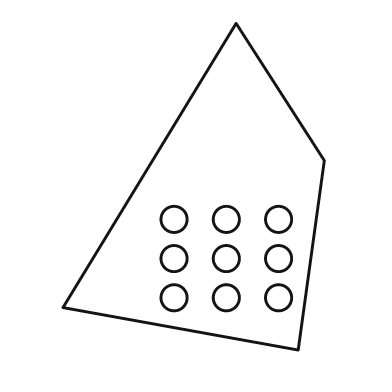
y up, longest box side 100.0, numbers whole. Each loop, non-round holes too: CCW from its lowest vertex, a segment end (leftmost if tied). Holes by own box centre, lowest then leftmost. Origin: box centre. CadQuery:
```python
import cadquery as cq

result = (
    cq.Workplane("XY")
    .moveTo(32.0, -50.0)
    .lineTo(40.0, 8.0)
    .lineTo(13.0, 50.0)
    .lineTo(-40.0, -37.0)
    .close()
    .moveTo(-6.0, -34.0)
    .circle(4.0)
    .moveTo(10.0, -34.0)
    .circle(4.0)
    .moveTo(26.0, -34.0)
    .circle(4.0)
    .moveTo(-6.0, -22.0)
    .circle(4.0)
    .moveTo(10.0, -22.0)
    .circle(4.0)
    .moveTo(26.0, -22.0)
    .circle(4.0)
    .moveTo(-6.0, -10.0)
    .circle(4.0)
    .moveTo(10.0, -10.0)
    .circle(4.0)
    .moveTo(26.0, -10.0)
    .circle(4.0)
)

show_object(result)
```